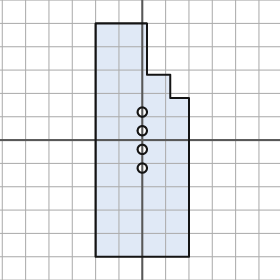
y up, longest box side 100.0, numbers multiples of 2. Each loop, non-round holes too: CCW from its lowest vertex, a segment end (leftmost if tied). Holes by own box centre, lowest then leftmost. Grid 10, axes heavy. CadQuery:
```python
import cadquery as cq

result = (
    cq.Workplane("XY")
    .moveTo(-20.0, -50.0)
    .lineTo(20.0, -50.0)
    .lineTo(20.0, 18.0)
    .lineTo(12.0, 18.0)
    .lineTo(12.0, 28.0)
    .lineTo(2.0, 28.0)
    .lineTo(2.0, 50.0)
    .lineTo(-20.0, 50.0)
    .close()
    .moveTo(0.0, -12.0)
    .circle(2.0)
    .moveTo(0.0, -4.0)
    .circle(2.0)
    .moveTo(0.0, 4.0)
    .circle(2.0)
    .moveTo(0.0, 12.0)
    .circle(2.0)
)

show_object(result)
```